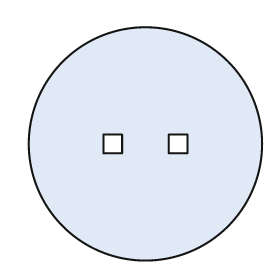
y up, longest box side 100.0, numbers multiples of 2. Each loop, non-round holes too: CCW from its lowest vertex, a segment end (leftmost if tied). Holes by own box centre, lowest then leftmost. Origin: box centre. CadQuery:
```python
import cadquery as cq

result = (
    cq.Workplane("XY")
    .moveTo(0.0, 0.0)
    .circle(50.0)
    .moveTo(-18.0, -4.0)
    .lineTo(-10.0, -4.0)
    .lineTo(-10.0, 4.0)
    .lineTo(-18.0, 4.0)
    .close()
    .moveTo(10.0, -4.0)
    .lineTo(18.0, -4.0)
    .lineTo(18.0, 4.0)
    .lineTo(10.0, 4.0)
    .close()
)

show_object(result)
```